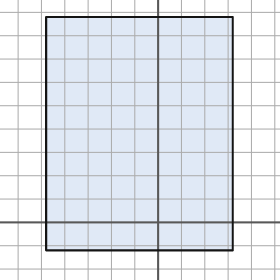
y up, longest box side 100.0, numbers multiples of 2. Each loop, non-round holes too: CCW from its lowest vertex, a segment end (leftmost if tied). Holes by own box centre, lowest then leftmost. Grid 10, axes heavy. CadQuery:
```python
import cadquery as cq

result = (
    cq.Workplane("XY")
    .moveTo(-48.0, -12.0)
    .lineTo(32.0, -12.0)
    .lineTo(32.0, 88.0)
    .lineTo(-48.0, 88.0)
    .close()
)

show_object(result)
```